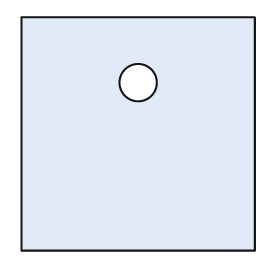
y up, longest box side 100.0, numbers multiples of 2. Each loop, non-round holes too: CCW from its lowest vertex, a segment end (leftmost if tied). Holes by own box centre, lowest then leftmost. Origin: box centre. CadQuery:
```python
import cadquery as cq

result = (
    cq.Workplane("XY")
    .moveTo(-50.0, -50.0)
    .lineTo(50.0, -50.0)
    .lineTo(50.0, 50.0)
    .lineTo(-50.0, 50.0)
    .close()
    .moveTo(0.0, 22.0)
    .circle(8.0)
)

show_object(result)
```